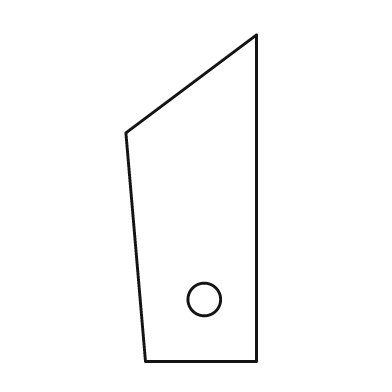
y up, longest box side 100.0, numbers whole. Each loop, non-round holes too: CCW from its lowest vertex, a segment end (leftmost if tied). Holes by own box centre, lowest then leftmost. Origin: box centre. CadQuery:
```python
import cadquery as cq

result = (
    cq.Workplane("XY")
    .moveTo(-14.0, -50.0)
    .lineTo(20.0, -50.0)
    .lineTo(20.0, 50.0)
    .lineTo(-20.0, 20.0)
    .close()
    .moveTo(4.0, -31.0)
    .circle(5.0)
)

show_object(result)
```